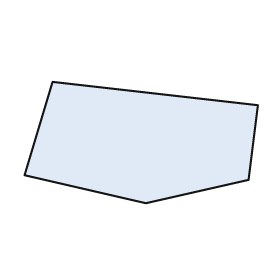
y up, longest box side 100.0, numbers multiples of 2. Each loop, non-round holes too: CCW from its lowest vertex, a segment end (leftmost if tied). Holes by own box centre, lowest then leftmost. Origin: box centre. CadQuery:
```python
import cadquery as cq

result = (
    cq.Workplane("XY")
    .moveTo(2.0, -26.0)
    .lineTo(46.0, -16.0)
    .lineTo(50.0, 16.0)
    .lineTo(-38.0, 26.0)
    .lineTo(-50.0, -14.0)
    .close()
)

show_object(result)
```